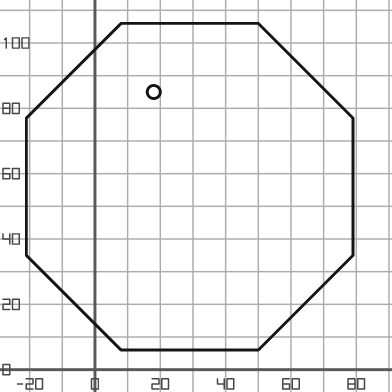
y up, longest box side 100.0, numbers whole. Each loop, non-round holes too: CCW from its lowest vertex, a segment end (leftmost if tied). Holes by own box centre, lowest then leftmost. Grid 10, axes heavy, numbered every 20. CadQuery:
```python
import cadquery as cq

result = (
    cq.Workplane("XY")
    .moveTo(8.0, 6.0)
    .lineTo(50.0, 6.0)
    .lineTo(79.0, 35.0)
    .lineTo(79.0, 77.0)
    .lineTo(50.0, 106.0)
    .lineTo(8.0, 106.0)
    .lineTo(-21.0, 77.0)
    .lineTo(-21.0, 35.0)
    .close()
    .moveTo(18.0, 85.0)
    .circle(2.0)
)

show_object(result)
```